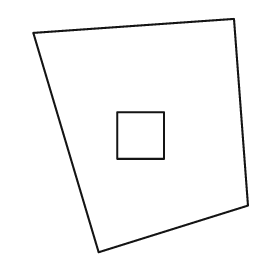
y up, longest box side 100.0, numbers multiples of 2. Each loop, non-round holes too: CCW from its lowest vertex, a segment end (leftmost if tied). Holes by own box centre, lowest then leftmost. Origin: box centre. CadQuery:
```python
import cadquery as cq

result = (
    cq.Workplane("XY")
    .moveTo(-18.0, -50.0)
    .lineTo(46.0, -30.0)
    .lineTo(40.0, 50.0)
    .lineTo(-46.0, 44.0)
    .close()
    .moveTo(-10.0, -10.0)
    .lineTo(10.0, -10.0)
    .lineTo(10.0, 10.0)
    .lineTo(-10.0, 10.0)
    .close()
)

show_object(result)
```